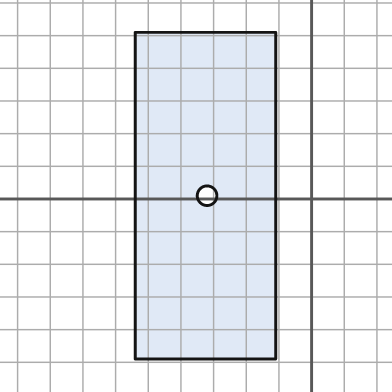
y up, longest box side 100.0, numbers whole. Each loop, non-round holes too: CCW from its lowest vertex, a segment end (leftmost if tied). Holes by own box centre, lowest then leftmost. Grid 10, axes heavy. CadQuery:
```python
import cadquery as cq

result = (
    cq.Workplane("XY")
    .moveTo(-54.0, -49.0)
    .lineTo(-11.0, -49.0)
    .lineTo(-11.0, 51.0)
    .lineTo(-54.0, 51.0)
    .close()
    .moveTo(-32.0, 1.0)
    .circle(3.0)
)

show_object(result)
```